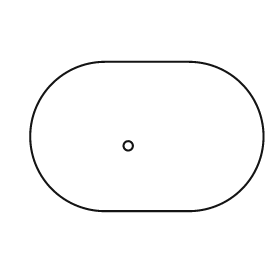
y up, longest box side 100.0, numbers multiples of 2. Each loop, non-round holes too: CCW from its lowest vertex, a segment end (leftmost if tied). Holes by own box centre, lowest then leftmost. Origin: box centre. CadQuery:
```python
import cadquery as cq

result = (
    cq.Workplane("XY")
    .moveTo(-18.0, -32.0)
    .lineTo(18.0, -32.0)
    .threePointArc((50.0, 0.0), (18.0, 32.0))
    .lineTo(-18.0, 32.0)
    .threePointArc((-50.0, 0.0), (-18.0, -32.0))
    .close()
    .moveTo(-8.0, -4.0)
    .circle(2.0)
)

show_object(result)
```